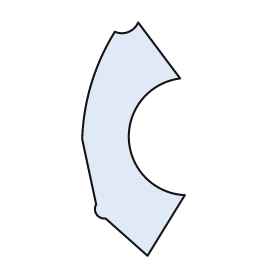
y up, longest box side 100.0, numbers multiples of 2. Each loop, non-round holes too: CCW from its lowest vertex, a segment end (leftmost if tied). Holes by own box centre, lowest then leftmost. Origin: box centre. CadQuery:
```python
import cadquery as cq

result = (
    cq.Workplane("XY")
    .moveTo(6.0, -50.0)
    .lineTo(22.0, -24.0)
    .threePointArc((-2.0, 0.0), (20.0, 26.0))
    .lineTo(2.0, 50.0)
    .threePointArc((-2.0, 46.0), (-8.0, 46.0))
    .threePointArc((-18.0, 24.0), (-22.0, 0.0))
    .lineTo(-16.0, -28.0)
    .threePointArc((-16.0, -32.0), (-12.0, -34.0))
    .close()
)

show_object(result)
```